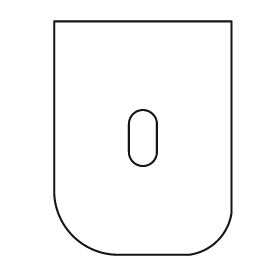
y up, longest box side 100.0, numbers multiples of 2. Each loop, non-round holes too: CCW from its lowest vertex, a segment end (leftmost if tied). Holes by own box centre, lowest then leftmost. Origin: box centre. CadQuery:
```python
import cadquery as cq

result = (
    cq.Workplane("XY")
    .moveTo(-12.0, -50.0)
    .lineTo(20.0, -50.0)
    .threePointArc((32.0, -44.0), (38.0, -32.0))
    .lineTo(38.0, 50.0)
    .lineTo(-38.0, 50.0)
    .lineTo(-38.0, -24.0)
    .threePointArc((-30.0, -42.0), (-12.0, -50.0))
    .close()
    .moveTo(-6.0, -6.0)
    .threePointArc((0.0, -12.0), (6.0, -6.0))
    .lineTo(6.0, 6.0)
    .threePointArc((0.0, 12.0), (-6.0, 6.0))
    .close()
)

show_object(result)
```